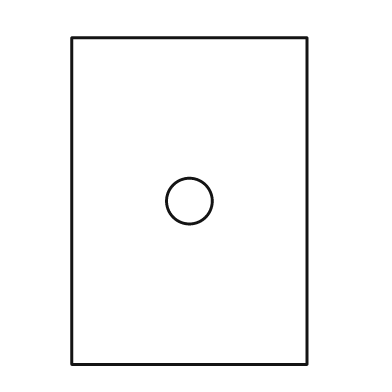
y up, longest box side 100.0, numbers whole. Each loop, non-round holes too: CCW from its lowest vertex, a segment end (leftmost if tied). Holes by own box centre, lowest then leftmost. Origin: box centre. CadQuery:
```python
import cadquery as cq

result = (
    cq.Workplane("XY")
    .moveTo(-36.0, -50.0)
    .lineTo(36.0, -50.0)
    .lineTo(36.0, 50.0)
    .lineTo(-36.0, 50.0)
    .close()
    .moveTo(0.0, 0.0)
    .circle(7.0)
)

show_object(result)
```